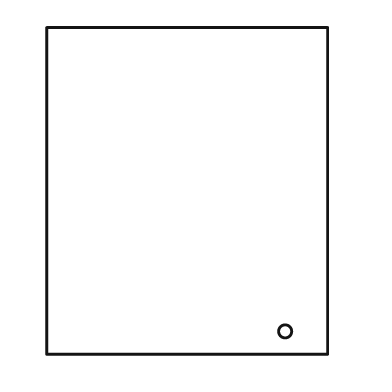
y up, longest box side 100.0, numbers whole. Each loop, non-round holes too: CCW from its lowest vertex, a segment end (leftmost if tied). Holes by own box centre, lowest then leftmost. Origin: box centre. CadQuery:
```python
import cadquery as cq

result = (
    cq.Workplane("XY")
    .moveTo(-43.0, -50.0)
    .lineTo(43.0, -50.0)
    .lineTo(43.0, 50.0)
    .lineTo(-43.0, 50.0)
    .close()
    .moveTo(30.0, -43.0)
    .circle(2.0)
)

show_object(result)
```